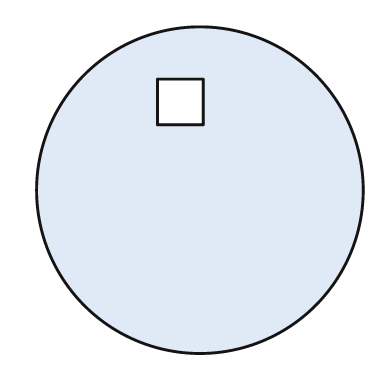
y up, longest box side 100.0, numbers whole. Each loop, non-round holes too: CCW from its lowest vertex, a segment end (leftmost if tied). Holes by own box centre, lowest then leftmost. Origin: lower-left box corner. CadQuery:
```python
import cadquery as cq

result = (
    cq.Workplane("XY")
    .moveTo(50.0, 50.0)
    .circle(50.0)
    .moveTo(37.0, 70.0)
    .lineTo(51.0, 70.0)
    .lineTo(51.0, 84.0)
    .lineTo(37.0, 84.0)
    .close()
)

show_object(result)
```